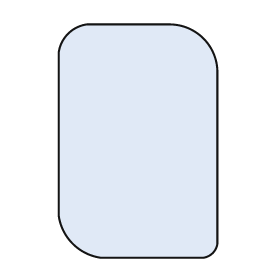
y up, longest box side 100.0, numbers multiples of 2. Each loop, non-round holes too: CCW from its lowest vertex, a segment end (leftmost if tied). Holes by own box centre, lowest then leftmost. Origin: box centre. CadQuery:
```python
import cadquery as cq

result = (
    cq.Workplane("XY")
    .moveTo(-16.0, -50.0)
    .lineTo(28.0, -50.0)
    .threePointArc((32.0, -48.0), (34.0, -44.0))
    .lineTo(34.0, 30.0)
    .threePointArc((28.0, 44.0), (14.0, 50.0))
    .lineTo(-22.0, 50.0)
    .threePointArc((-30.0, 46.0), (-34.0, 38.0))
    .lineTo(-34.0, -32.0)
    .threePointArc((-28.0, -44.0), (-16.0, -50.0))
    .close()
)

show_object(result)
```